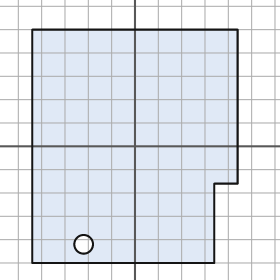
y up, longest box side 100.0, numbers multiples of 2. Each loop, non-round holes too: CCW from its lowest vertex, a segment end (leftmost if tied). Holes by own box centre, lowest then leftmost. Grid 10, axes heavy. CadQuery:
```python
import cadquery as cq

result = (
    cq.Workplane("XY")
    .moveTo(-44.0, -50.0)
    .lineTo(34.0, -50.0)
    .lineTo(34.0, -16.0)
    .lineTo(44.0, -16.0)
    .lineTo(44.0, 50.0)
    .lineTo(-44.0, 50.0)
    .close()
    .moveTo(-22.0, -42.0)
    .circle(4.0)
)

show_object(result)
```